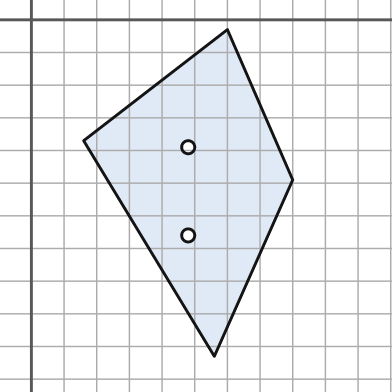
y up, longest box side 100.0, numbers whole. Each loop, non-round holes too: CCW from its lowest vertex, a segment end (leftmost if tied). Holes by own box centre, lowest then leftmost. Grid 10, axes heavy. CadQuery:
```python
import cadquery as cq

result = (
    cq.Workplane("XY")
    .moveTo(56.0, -103.0)
    .lineTo(80.0, -49.0)
    .lineTo(60.0, -3.0)
    .lineTo(16.0, -37.0)
    .close()
    .moveTo(48.0, -66.0)
    .circle(2.0)
    .moveTo(48.0, -39.0)
    .circle(2.0)
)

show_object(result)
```